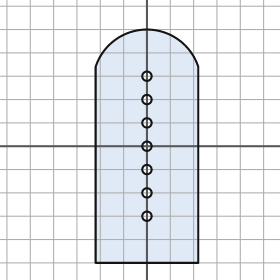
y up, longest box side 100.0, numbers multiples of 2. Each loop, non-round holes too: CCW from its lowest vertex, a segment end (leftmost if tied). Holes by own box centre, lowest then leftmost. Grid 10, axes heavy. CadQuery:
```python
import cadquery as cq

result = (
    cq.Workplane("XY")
    .moveTo(-22.0, -50.0)
    .lineTo(22.0, -50.0)
    .lineTo(22.0, 34.0)
    .threePointArc((0.0, 50.0), (-22.0, 34.0))
    .close()
    .moveTo(0.0, -30.0)
    .circle(2.0)
    .moveTo(0.0, -20.0)
    .circle(2.0)
    .moveTo(0.0, -10.0)
    .circle(2.0)
    .moveTo(0.0, 0.0)
    .circle(2.0)
    .moveTo(0.0, 10.0)
    .circle(2.0)
    .moveTo(0.0, 20.0)
    .circle(2.0)
    .moveTo(0.0, 30.0)
    .circle(2.0)
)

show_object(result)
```